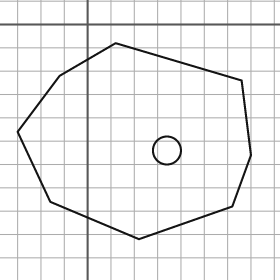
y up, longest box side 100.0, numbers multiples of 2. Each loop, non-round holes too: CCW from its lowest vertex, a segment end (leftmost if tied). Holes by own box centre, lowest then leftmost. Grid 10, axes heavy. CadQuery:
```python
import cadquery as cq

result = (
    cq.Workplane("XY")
    .moveTo(22.0, -92.0)
    .lineTo(62.0, -78.0)
    .lineTo(70.0, -56.0)
    .lineTo(66.0, -24.0)
    .lineTo(12.0, -8.0)
    .lineTo(-12.0, -22.0)
    .lineTo(-30.0, -46.0)
    .lineTo(-16.0, -76.0)
    .close()
    .moveTo(34.0, -54.0)
    .circle(6.0)
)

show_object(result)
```